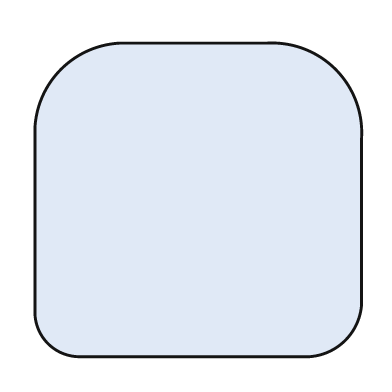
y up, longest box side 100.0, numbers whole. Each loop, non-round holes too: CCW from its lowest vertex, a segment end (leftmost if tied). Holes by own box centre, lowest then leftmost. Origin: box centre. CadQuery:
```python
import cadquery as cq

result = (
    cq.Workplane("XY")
    .moveTo(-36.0, -48.0)
    .lineTo(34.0, -48.0)
    .threePointArc((45.0, -43.0), (50.0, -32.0))
    .lineTo(50.0, 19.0)
    .threePointArc((42.0, 40.0), (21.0, 48.0))
    .lineTo(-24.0, 48.0)
    .threePointArc((-42.0, 40.0), (-50.0, 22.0))
    .lineTo(-50.0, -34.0)
    .threePointArc((-46.0, -44.0), (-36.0, -48.0))
    .close()
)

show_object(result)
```